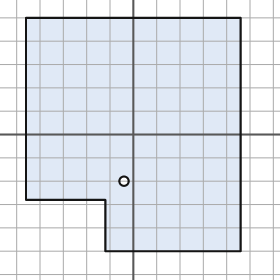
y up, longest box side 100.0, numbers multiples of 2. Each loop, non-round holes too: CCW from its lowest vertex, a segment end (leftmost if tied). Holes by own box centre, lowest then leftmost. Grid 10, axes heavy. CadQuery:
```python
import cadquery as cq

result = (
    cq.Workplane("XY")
    .moveTo(-12.0, -50.0)
    .lineTo(46.0, -50.0)
    .lineTo(46.0, 50.0)
    .lineTo(-46.0, 50.0)
    .lineTo(-46.0, -28.0)
    .lineTo(-12.0, -28.0)
    .close()
    .moveTo(-4.0, -20.0)
    .circle(2.0)
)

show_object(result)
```